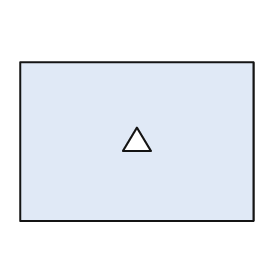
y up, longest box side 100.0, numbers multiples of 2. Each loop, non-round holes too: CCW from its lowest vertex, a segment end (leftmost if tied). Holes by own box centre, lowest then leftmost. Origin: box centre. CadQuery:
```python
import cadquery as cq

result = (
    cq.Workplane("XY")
    .moveTo(-50.0, -34.0)
    .lineTo(50.0, -34.0)
    .lineTo(50.0, 34.0)
    .lineTo(-50.0, 34.0)
    .close()
    .moveTo(-6.0, -4.0)
    .lineTo(6.0, -4.0)
    .lineTo(0.0, 6.0)
    .close()
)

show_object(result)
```